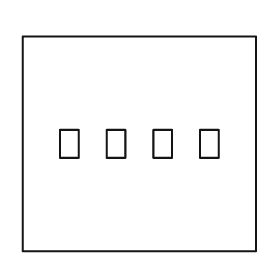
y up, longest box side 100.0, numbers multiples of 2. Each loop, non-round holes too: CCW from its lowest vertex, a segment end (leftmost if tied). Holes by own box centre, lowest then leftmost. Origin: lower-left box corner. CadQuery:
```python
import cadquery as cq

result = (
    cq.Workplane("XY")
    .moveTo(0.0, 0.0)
    .lineTo(100.0, 0.0)
    .lineTo(100.0, 92.0)
    .lineTo(0.0, 92.0)
    .close()
    .moveTo(16.0, 40.0)
    .lineTo(24.0, 40.0)
    .lineTo(24.0, 52.0)
    .lineTo(16.0, 52.0)
    .close()
    .moveTo(36.0, 40.0)
    .lineTo(44.0, 40.0)
    .lineTo(44.0, 52.0)
    .lineTo(36.0, 52.0)
    .close()
    .moveTo(56.0, 40.0)
    .lineTo(64.0, 40.0)
    .lineTo(64.0, 52.0)
    .lineTo(56.0, 52.0)
    .close()
    .moveTo(76.0, 40.0)
    .lineTo(84.0, 40.0)
    .lineTo(84.0, 52.0)
    .lineTo(76.0, 52.0)
    .close()
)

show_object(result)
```